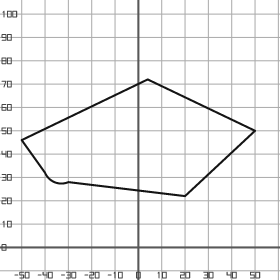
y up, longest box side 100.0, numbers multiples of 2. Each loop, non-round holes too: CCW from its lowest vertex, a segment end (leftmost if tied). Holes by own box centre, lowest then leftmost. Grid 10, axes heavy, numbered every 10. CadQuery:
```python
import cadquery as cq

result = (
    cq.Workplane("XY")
    .moveTo(20.0, 22.0)
    .lineTo(50.0, 50.0)
    .lineTo(4.0, 72.0)
    .lineTo(-50.0, 46.0)
    .lineTo(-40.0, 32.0)
    .threePointArc((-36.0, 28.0), (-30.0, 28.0))
    .close()
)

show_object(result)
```